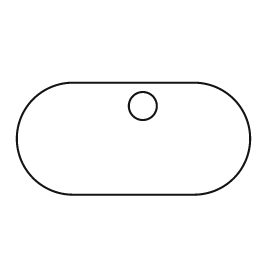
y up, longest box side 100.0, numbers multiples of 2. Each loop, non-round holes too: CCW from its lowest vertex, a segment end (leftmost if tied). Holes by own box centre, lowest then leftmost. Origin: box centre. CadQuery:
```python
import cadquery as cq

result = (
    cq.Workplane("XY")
    .moveTo(-26.0, -24.0)
    .lineTo(26.0, -24.0)
    .threePointArc((50.0, 0.0), (26.0, 24.0))
    .lineTo(-26.0, 24.0)
    .threePointArc((-50.0, 0.0), (-26.0, -24.0))
    .close()
    .moveTo(4.0, 14.0)
    .circle(6.0)
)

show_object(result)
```